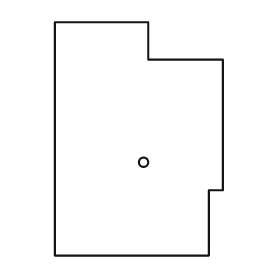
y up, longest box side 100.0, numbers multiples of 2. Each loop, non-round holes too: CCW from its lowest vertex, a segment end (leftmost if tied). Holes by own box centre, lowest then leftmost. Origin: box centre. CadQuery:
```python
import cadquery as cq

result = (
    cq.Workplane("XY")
    .moveTo(-36.0, -50.0)
    .lineTo(30.0, -50.0)
    .lineTo(30.0, -22.0)
    .lineTo(36.0, -22.0)
    .lineTo(36.0, 34.0)
    .lineTo(4.0, 34.0)
    .lineTo(4.0, 50.0)
    .lineTo(-36.0, 50.0)
    .close()
    .moveTo(2.0, -10.0)
    .circle(2.0)
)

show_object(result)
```